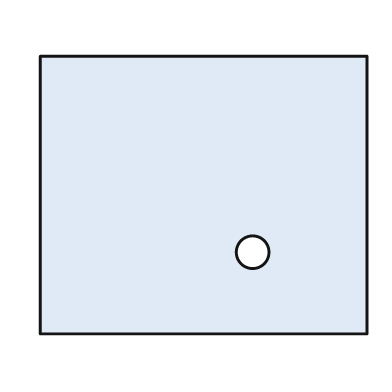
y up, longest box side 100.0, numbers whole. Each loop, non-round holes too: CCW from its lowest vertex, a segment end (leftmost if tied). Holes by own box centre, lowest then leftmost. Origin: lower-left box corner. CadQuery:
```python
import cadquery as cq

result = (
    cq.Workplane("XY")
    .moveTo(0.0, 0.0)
    .lineTo(100.0, 0.0)
    .lineTo(100.0, 85.0)
    .lineTo(0.0, 85.0)
    .close()
    .moveTo(65.0, 25.0)
    .circle(5.0)
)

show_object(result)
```